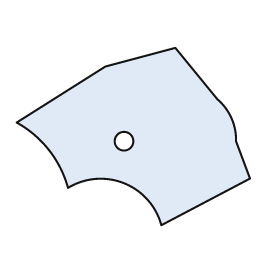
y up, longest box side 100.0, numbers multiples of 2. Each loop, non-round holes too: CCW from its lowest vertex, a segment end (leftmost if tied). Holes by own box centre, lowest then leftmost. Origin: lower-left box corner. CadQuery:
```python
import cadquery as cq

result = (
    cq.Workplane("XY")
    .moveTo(62.0, 0.0)
    .lineTo(100.0, 20.0)
    .lineTo(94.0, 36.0)
    .threePointArc((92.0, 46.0), (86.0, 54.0))
    .lineTo(68.0, 76.0)
    .lineTo(38.0, 68.0)
    .lineTo(0.0, 44.0)
    .threePointArc((14.0, 32.0), (22.0, 16.0))
    .threePointArc((46.0, 18.0), (62.0, 0.0))
    .close()
    .moveTo(46.0, 36.0)
    .circle(4.0)
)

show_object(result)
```